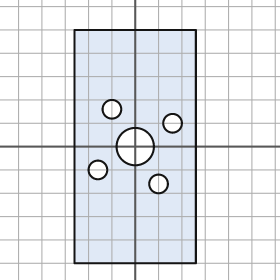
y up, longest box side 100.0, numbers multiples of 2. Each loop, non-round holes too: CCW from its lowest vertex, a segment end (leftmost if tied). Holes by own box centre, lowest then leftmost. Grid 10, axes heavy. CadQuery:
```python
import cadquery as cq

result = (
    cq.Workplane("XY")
    .moveTo(-26.0, -50.0)
    .lineTo(26.0, -50.0)
    .lineTo(26.0, 50.0)
    .lineTo(-26.0, 50.0)
    .close()
    .moveTo(10.0, -16.0)
    .circle(4.0)
    .moveTo(-16.0, -10.0)
    .circle(4.0)
    .moveTo(0.0, 0.0)
    .circle(8.0)
    .moveTo(16.0, 10.0)
    .circle(4.0)
    .moveTo(-10.0, 16.0)
    .circle(4.0)
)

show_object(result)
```